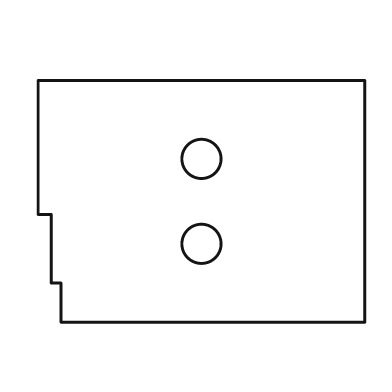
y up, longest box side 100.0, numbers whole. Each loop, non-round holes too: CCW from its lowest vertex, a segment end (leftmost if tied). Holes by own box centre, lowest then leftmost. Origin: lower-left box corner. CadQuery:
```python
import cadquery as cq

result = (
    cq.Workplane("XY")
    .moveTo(7.0, 0.0)
    .lineTo(100.0, 0.0)
    .lineTo(100.0, 74.0)
    .lineTo(0.0, 74.0)
    .lineTo(0.0, 33.0)
    .lineTo(4.0, 33.0)
    .lineTo(4.0, 12.0)
    .lineTo(7.0, 12.0)
    .close()
    .moveTo(50.0, 24.0)
    .circle(6.0)
    .moveTo(50.0, 50.0)
    .circle(6.0)
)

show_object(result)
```